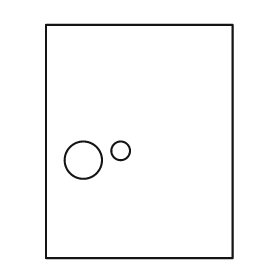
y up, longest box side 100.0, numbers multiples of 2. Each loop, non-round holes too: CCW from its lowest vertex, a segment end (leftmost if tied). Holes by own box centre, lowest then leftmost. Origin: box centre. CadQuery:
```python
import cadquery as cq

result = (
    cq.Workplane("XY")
    .moveTo(-40.0, -50.0)
    .lineTo(40.0, -50.0)
    .lineTo(40.0, 50.0)
    .lineTo(-40.0, 50.0)
    .close()
    .moveTo(-24.0, -8.0)
    .circle(8.0)
    .moveTo(-8.0, -4.0)
    .circle(4.0)
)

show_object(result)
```